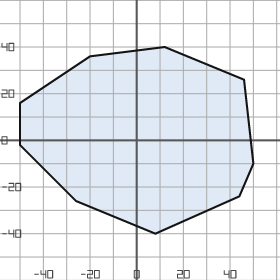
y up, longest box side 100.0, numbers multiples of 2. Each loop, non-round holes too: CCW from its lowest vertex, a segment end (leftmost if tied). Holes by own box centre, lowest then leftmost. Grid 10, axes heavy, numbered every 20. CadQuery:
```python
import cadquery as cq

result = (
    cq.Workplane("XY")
    .moveTo(8.0, -40.0)
    .lineTo(44.0, -24.0)
    .lineTo(50.0, -10.0)
    .lineTo(46.0, 26.0)
    .lineTo(12.0, 40.0)
    .lineTo(-20.0, 36.0)
    .lineTo(-50.0, 16.0)
    .lineTo(-50.0, -2.0)
    .lineTo(-26.0, -26.0)
    .close()
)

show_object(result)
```